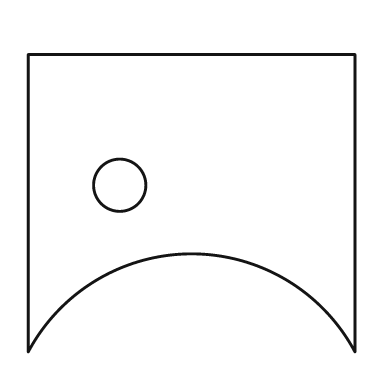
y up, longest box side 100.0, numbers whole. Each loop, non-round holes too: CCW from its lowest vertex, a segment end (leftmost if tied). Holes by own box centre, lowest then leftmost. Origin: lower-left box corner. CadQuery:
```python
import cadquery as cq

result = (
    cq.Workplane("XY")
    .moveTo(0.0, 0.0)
    .threePointArc((50.0, 30.0), (100.0, 0.0))
    .lineTo(100.0, 91.0)
    .lineTo(0.0, 91.0)
    .close()
    .moveTo(28.0, 51.0)
    .circle(8.0)
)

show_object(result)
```